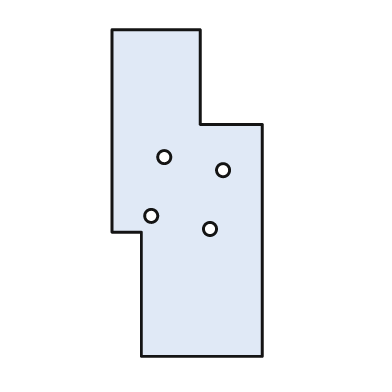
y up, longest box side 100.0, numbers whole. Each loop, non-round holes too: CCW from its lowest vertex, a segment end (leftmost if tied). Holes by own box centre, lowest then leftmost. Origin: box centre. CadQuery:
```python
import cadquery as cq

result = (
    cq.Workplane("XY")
    .moveTo(-14.0, -50.0)
    .lineTo(23.0, -50.0)
    .lineTo(23.0, 21.0)
    .lineTo(4.0, 21.0)
    .lineTo(4.0, 50.0)
    .lineTo(-23.0, 50.0)
    .lineTo(-23.0, -12.0)
    .lineTo(-14.0, -12.0)
    .close()
    .moveTo(7.0, -11.0)
    .circle(2.0)
    .moveTo(-11.0, -7.0)
    .circle(2.0)
    .moveTo(11.0, 7.0)
    .circle(2.0)
    .moveTo(-7.0, 11.0)
    .circle(2.0)
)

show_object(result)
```